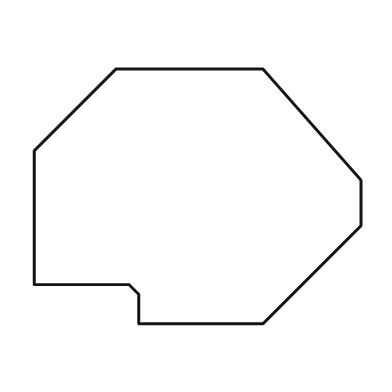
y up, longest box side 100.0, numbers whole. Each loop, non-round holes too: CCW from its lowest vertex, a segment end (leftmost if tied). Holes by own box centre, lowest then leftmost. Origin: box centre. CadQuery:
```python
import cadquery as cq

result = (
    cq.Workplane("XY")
    .moveTo(-18.0, -39.0)
    .lineTo(20.0, -39.0)
    .lineTo(50.0, -9.0)
    .lineTo(50.0, 5.0)
    .lineTo(20.0, 39.0)
    .lineTo(-25.0, 39.0)
    .lineTo(-50.0, 14.0)
    .lineTo(-50.0, -27.0)
    .lineTo(-21.0, -27.0)
    .lineTo(-18.0, -30.0)
    .close()
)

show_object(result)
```